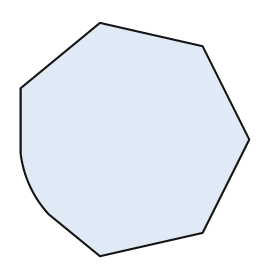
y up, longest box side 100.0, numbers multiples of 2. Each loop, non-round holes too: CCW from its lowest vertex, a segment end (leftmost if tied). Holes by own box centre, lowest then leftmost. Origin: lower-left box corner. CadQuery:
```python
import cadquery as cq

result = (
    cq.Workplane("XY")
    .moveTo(34.0, 0.0)
    .lineTo(78.0, 10.0)
    .lineTo(98.0, 50.0)
    .lineTo(78.0, 90.0)
    .lineTo(34.0, 100.0)
    .lineTo(0.0, 72.0)
    .lineTo(0.0, 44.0)
    .threePointArc((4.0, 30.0), (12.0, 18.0))
    .close()
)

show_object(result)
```